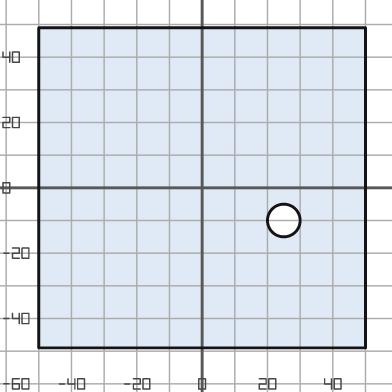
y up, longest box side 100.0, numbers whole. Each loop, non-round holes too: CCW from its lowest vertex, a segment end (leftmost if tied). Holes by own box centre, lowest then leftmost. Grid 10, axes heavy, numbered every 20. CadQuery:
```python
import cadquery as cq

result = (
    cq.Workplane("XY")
    .moveTo(-50.0, -49.0)
    .lineTo(50.0, -49.0)
    .lineTo(50.0, 49.0)
    .lineTo(-50.0, 49.0)
    .close()
    .moveTo(25.0, -10.0)
    .circle(5.0)
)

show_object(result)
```